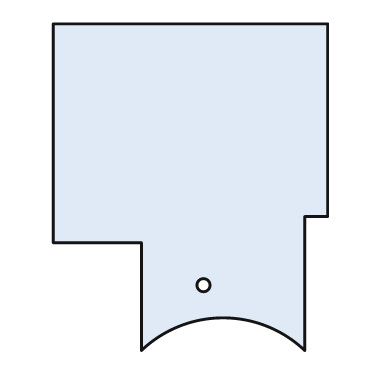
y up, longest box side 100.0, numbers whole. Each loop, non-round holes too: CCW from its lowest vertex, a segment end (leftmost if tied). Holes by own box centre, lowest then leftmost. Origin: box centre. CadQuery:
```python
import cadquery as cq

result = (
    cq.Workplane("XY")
    .moveTo(-15.0, -50.0)
    .threePointArc((10.0, -40.0), (35.0, -50.0))
    .lineTo(35.0, -9.0)
    .lineTo(42.0, -9.0)
    .lineTo(42.0, 50.0)
    .lineTo(-42.0, 50.0)
    .lineTo(-42.0, -17.0)
    .lineTo(-15.0, -17.0)
    .close()
    .moveTo(4.0, -30.0)
    .circle(2.0)
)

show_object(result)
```